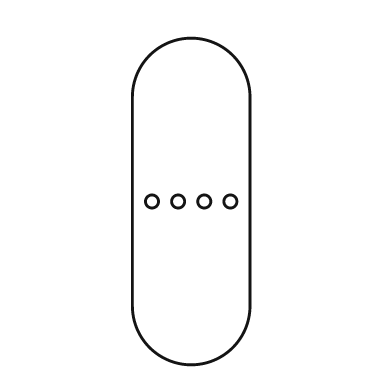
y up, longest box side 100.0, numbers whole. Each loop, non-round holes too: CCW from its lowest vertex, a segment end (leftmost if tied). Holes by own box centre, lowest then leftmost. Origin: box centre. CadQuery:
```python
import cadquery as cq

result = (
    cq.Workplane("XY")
    .moveTo(-18.0, -32.0)
    .threePointArc((0.0, -50.0), (18.0, -32.0))
    .lineTo(18.0, 32.0)
    .threePointArc((0.0, 50.0), (-18.0, 32.0))
    .close()
    .moveTo(-12.0, 0.0)
    .circle(2.0)
    .moveTo(-4.0, 0.0)
    .circle(2.0)
    .moveTo(4.0, 0.0)
    .circle(2.0)
    .moveTo(12.0, 0.0)
    .circle(2.0)
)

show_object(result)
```